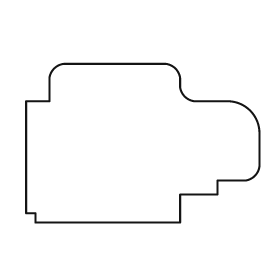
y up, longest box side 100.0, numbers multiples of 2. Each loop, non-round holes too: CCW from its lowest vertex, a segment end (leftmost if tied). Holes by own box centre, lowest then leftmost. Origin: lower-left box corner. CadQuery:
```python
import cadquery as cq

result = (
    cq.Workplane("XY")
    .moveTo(4.0, 0.0)
    .lineTo(66.0, 0.0)
    .lineTo(66.0, 12.0)
    .lineTo(82.0, 12.0)
    .lineTo(82.0, 18.0)
    .lineTo(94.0, 18.0)
    .threePointArc((98.0, 20.0), (100.0, 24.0))
    .lineTo(100.0, 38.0)
    .threePointArc((96.0, 48.0), (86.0, 52.0))
    .lineTo(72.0, 52.0)
    .threePointArc((68.0, 54.0), (66.0, 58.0))
    .lineTo(66.0, 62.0)
    .threePointArc((64.0, 66.0), (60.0, 68.0))
    .lineTo(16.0, 68.0)
    .threePointArc((12.0, 66.0), (10.0, 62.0))
    .lineTo(10.0, 52.0)
    .lineTo(0.0, 52.0)
    .lineTo(0.0, 4.0)
    .lineTo(4.0, 4.0)
    .close()
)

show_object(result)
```